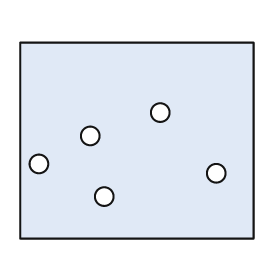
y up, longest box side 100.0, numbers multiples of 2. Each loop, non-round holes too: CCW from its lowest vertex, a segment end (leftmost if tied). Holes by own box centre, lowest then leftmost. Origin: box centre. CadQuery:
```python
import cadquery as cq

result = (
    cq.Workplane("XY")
    .moveTo(-50.0, -42.0)
    .lineTo(50.0, -42.0)
    .lineTo(50.0, 42.0)
    .lineTo(-50.0, 42.0)
    .close()
    .moveTo(-14.0, -24.0)
    .circle(4.0)
    .moveTo(34.0, -14.0)
    .circle(4.0)
    .moveTo(-42.0, -10.0)
    .circle(4.0)
    .moveTo(-20.0, 2.0)
    .circle(4.0)
    .moveTo(10.0, 12.0)
    .circle(4.0)
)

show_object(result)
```